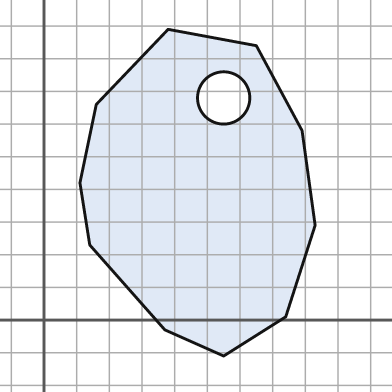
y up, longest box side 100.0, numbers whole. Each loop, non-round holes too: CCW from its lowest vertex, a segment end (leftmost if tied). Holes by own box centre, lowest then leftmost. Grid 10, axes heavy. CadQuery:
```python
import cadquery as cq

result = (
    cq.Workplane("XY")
    .moveTo(55.0, -11.0)
    .lineTo(74.0, 1.0)
    .lineTo(83.0, 29.0)
    .lineTo(79.0, 58.0)
    .lineTo(65.0, 84.0)
    .lineTo(38.0, 89.0)
    .lineTo(16.0, 66.0)
    .lineTo(11.0, 42.0)
    .lineTo(14.0, 23.0)
    .lineTo(37.0, -3.0)
    .close()
    .moveTo(55.0, 68.0)
    .circle(8.0)
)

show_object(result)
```